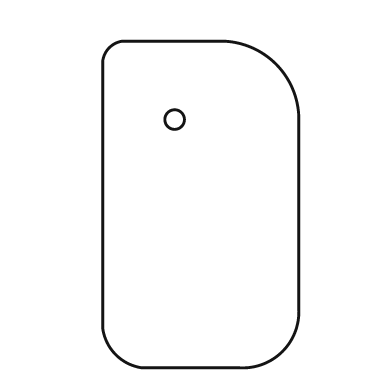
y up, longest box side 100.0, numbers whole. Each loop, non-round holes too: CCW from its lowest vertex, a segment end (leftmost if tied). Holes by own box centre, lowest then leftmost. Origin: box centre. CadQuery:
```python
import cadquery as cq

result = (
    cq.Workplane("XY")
    .moveTo(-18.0, -50.0)
    .lineTo(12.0, -50.0)
    .threePointArc((25.0, -45.0), (30.0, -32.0))
    .lineTo(30.0, 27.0)
    .threePointArc((23.0, 43.0), (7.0, 50.0))
    .lineTo(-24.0, 50.0)
    .threePointArc((-28.0, 48.0), (-30.0, 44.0))
    .lineTo(-30.0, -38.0)
    .threePointArc((-26.0, -46.0), (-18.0, -50.0))
    .close()
    .moveTo(-8.0, 26.0)
    .circle(3.0)
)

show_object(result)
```